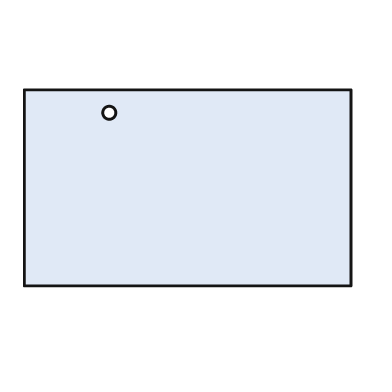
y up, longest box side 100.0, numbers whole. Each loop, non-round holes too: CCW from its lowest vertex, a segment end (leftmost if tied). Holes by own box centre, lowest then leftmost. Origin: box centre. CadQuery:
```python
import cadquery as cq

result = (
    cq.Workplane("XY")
    .moveTo(-50.0, -30.0)
    .lineTo(50.0, -30.0)
    .lineTo(50.0, 30.0)
    .lineTo(-50.0, 30.0)
    .close()
    .moveTo(-24.0, 23.0)
    .circle(2.0)
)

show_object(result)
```